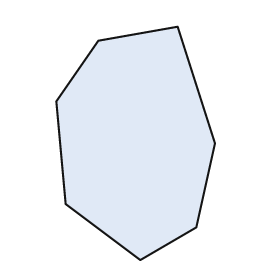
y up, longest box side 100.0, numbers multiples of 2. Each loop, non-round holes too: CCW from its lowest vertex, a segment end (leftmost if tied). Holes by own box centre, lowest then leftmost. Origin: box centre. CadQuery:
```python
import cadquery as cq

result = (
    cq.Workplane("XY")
    .moveTo(2.0, -50.0)
    .lineTo(26.0, -36.0)
    .lineTo(34.0, 0.0)
    .lineTo(18.0, 50.0)
    .lineTo(-16.0, 44.0)
    .lineTo(-34.0, 18.0)
    .lineTo(-30.0, -26.0)
    .close()
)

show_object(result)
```